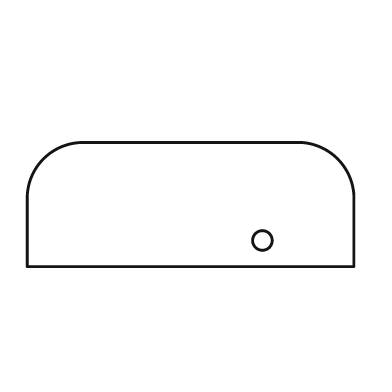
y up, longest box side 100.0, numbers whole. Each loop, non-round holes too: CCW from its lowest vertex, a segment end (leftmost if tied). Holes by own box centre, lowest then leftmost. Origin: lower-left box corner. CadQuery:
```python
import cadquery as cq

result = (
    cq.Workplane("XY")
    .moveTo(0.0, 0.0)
    .lineTo(100.0, 0.0)
    .lineTo(100.0, 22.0)
    .threePointArc((95.0, 33.0), (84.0, 38.0))
    .lineTo(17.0, 38.0)
    .threePointArc((5.0, 33.0), (0.0, 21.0))
    .close()
    .moveTo(72.0, 8.0)
    .circle(3.0)
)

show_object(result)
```